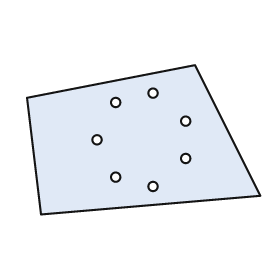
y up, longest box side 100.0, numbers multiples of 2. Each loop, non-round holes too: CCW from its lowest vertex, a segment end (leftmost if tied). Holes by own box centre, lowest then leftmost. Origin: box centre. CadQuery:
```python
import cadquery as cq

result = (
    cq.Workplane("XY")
    .moveTo(-44.0, -32.0)
    .lineTo(50.0, -24.0)
    .lineTo(22.0, 32.0)
    .lineTo(-50.0, 18.0)
    .close()
    .moveTo(4.0, -20.0)
    .circle(2.0)
    .moveTo(-12.0, -16.0)
    .circle(2.0)
    .moveTo(18.0, -8.0)
    .circle(2.0)
    .moveTo(-20.0, 0.0)
    .circle(2.0)
    .moveTo(18.0, 8.0)
    .circle(2.0)
    .moveTo(-12.0, 16.0)
    .circle(2.0)
    .moveTo(4.0, 20.0)
    .circle(2.0)
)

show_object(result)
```